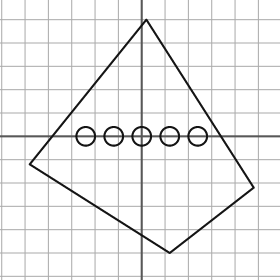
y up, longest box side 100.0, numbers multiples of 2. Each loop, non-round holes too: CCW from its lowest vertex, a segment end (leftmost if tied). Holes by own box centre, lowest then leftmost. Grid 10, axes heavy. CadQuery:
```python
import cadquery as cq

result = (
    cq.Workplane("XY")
    .moveTo(12.0, -50.0)
    .lineTo(48.0, -22.0)
    .lineTo(2.0, 50.0)
    .lineTo(-48.0, -12.0)
    .close()
    .moveTo(-24.0, 0.0)
    .circle(4.0)
    .moveTo(-12.0, 0.0)
    .circle(4.0)
    .moveTo(0.0, 0.0)
    .circle(4.0)
    .moveTo(12.0, 0.0)
    .circle(4.0)
    .moveTo(24.0, 0.0)
    .circle(4.0)
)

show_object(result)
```